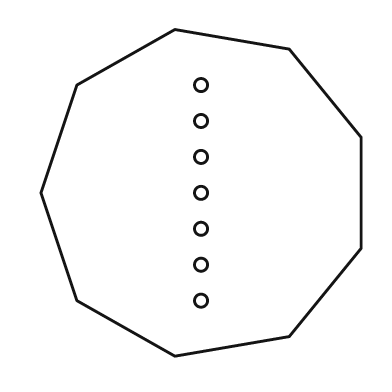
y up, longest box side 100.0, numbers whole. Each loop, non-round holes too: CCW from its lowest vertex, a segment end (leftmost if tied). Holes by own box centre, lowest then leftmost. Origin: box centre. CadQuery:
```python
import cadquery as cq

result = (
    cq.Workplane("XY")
    .moveTo(-8.0, -50.0)
    .lineTo(27.0, -44.0)
    .lineTo(49.0, -17.0)
    .lineTo(49.0, 17.0)
    .lineTo(27.0, 44.0)
    .lineTo(-8.0, 50.0)
    .lineTo(-38.0, 33.0)
    .lineTo(-49.0, 0.0)
    .lineTo(-38.0, -33.0)
    .close()
    .moveTo(0.0, -33.0)
    .circle(2.0)
    .moveTo(0.0, -22.0)
    .circle(2.0)
    .moveTo(0.0, -11.0)
    .circle(2.0)
    .moveTo(0.0, 0.0)
    .circle(2.0)
    .moveTo(0.0, 11.0)
    .circle(2.0)
    .moveTo(0.0, 22.0)
    .circle(2.0)
    .moveTo(0.0, 33.0)
    .circle(2.0)
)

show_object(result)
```